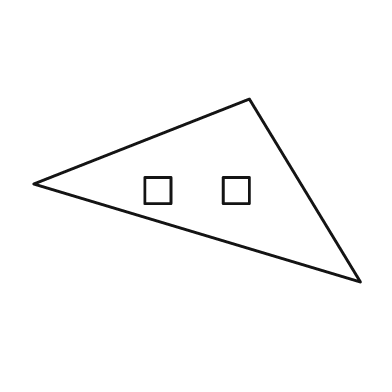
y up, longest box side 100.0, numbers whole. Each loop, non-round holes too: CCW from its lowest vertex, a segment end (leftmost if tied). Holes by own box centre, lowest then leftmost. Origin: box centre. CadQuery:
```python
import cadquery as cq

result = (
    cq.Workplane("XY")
    .moveTo(50.0, -28.0)
    .lineTo(16.0, 28.0)
    .lineTo(-50.0, 2.0)
    .close()
    .moveTo(-16.0, -4.0)
    .lineTo(-8.0, -4.0)
    .lineTo(-8.0, 4.0)
    .lineTo(-16.0, 4.0)
    .close()
    .moveTo(8.0, -4.0)
    .lineTo(16.0, -4.0)
    .lineTo(16.0, 4.0)
    .lineTo(8.0, 4.0)
    .close()
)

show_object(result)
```